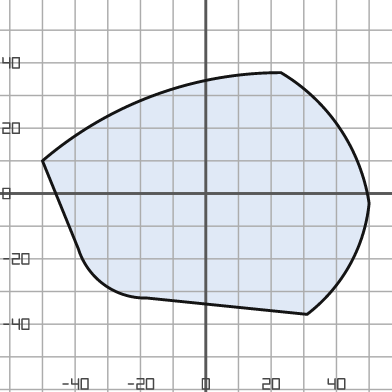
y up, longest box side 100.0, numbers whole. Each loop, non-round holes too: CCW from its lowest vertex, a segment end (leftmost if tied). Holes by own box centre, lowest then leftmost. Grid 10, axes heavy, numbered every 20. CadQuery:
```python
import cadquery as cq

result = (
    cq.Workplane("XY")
    .moveTo(31.0, -37.0)
    .threePointArc((44.0, -22.0), (50.0, -3.0))
    .threePointArc((41.0, 20.0), (23.0, 37.0))
    .threePointArc((-16.0, 30.0), (-50.0, 10.0))
    .lineTo(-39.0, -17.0)
    .threePointArc((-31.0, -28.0), (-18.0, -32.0))
    .close()
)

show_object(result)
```